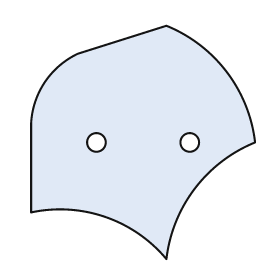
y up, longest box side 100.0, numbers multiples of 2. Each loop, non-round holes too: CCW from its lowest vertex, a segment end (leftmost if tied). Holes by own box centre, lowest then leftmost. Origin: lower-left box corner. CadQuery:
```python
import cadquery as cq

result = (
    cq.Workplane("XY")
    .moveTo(58.0, 0.0)
    .threePointArc((70.0, 30.0), (96.0, 50.0))
    .threePointArc((84.0, 80.0), (58.0, 100.0))
    .lineTo(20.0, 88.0)
    .threePointArc((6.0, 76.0), (0.0, 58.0))
    .lineTo(0.0, 20.0)
    .threePointArc((32.0, 18.0), (58.0, 0.0))
    .close()
    .moveTo(28.0, 50.0)
    .circle(4.0)
    .moveTo(68.0, 50.0)
    .circle(4.0)
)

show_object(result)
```